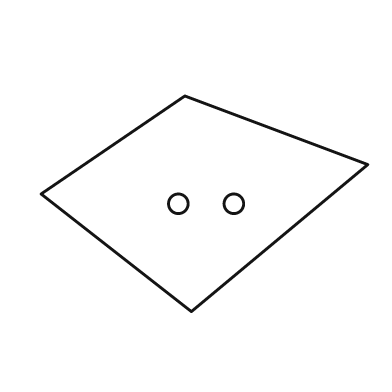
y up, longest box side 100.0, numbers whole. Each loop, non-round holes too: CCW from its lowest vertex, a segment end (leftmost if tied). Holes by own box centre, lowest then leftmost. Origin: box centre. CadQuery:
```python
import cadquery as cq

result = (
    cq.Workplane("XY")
    .moveTo(-4.0, -33.0)
    .lineTo(50.0, 12.0)
    .lineTo(-6.0, 33.0)
    .lineTo(-50.0, 3.0)
    .close()
    .moveTo(-8.0, 0.0)
    .circle(3.0)
    .moveTo(9.0, 0.0)
    .circle(3.0)
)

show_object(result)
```